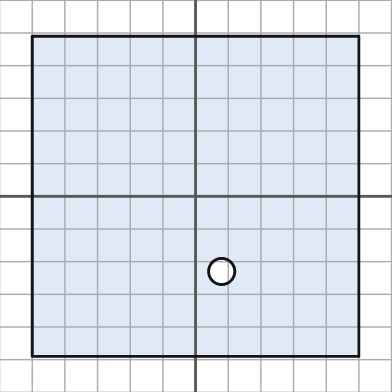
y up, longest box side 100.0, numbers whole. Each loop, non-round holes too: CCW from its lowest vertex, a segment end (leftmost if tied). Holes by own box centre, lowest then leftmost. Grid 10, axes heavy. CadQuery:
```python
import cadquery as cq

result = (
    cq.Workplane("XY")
    .moveTo(-50.0, -49.0)
    .lineTo(50.0, -49.0)
    .lineTo(50.0, 49.0)
    .lineTo(-50.0, 49.0)
    .close()
    .moveTo(8.0, -23.0)
    .circle(4.0)
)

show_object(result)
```